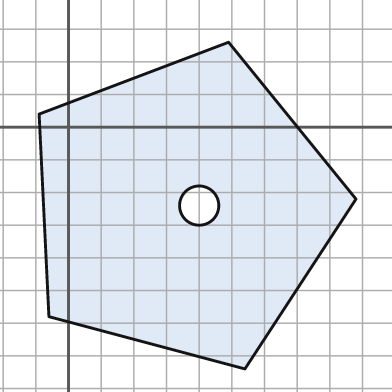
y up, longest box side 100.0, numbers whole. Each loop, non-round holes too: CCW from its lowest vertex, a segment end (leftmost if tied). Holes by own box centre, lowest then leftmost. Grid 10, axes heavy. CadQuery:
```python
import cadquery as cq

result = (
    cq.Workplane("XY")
    .moveTo(54.0, -74.0)
    .lineTo(88.0, -22.0)
    .lineTo(49.0, 26.0)
    .lineTo(-9.0, 4.0)
    .lineTo(-6.0, -58.0)
    .close()
    .moveTo(40.0, -24.0)
    .circle(6.0)
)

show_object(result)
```